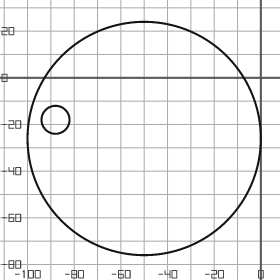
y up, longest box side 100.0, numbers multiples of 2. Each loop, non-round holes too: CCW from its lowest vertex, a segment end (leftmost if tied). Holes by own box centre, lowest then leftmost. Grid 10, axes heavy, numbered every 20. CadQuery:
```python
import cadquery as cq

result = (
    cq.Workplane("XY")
    .moveTo(-50.0, -26.0)
    .circle(50.0)
    .moveTo(-88.0, -18.0)
    .circle(6.0)
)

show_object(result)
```